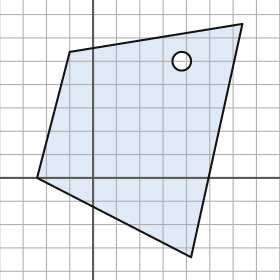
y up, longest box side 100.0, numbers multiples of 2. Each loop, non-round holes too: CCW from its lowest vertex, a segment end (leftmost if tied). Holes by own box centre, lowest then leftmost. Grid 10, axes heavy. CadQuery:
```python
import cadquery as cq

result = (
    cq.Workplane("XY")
    .moveTo(42.0, -34.0)
    .lineTo(64.0, 66.0)
    .lineTo(-10.0, 54.0)
    .lineTo(-24.0, 0.0)
    .close()
    .moveTo(38.0, 50.0)
    .circle(4.0)
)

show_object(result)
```